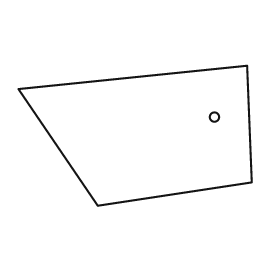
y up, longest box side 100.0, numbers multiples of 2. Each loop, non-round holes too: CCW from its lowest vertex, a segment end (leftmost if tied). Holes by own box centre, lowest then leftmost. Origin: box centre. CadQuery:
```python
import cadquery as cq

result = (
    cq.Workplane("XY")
    .moveTo(-16.0, -30.0)
    .lineTo(50.0, -20.0)
    .lineTo(48.0, 30.0)
    .lineTo(-50.0, 20.0)
    .close()
    .moveTo(34.0, 8.0)
    .circle(2.0)
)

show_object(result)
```